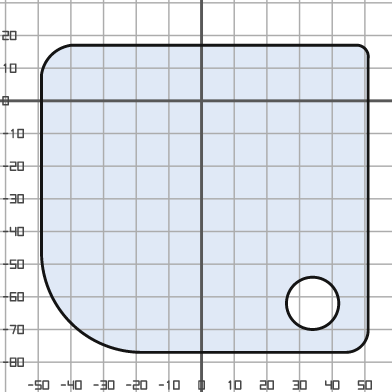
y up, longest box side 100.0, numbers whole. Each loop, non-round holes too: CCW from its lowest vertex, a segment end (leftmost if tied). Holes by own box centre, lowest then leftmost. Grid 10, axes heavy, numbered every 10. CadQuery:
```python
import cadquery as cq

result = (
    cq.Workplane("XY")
    .moveTo(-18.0, -77.0)
    .lineTo(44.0, -77.0)
    .threePointArc((49.0, -75.0), (51.0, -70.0))
    .lineTo(51.0, 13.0)
    .threePointArc((50.0, 16.0), (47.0, 17.0))
    .lineTo(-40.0, 17.0)
    .threePointArc((-46.0, 14.0), (-49.0, 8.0))
    .lineTo(-49.0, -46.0)
    .threePointArc((-40.0, -68.0), (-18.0, -77.0))
    .close()
    .moveTo(34.0, -62.0)
    .circle(8.0)
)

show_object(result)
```